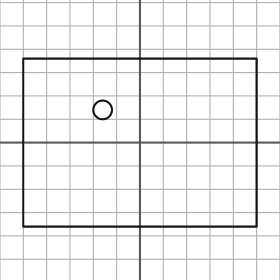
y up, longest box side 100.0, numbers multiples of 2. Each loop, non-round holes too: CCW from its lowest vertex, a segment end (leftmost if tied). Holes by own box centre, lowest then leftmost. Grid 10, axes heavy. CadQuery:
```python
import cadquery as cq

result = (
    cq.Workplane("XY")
    .moveTo(-50.0, -36.0)
    .lineTo(50.0, -36.0)
    .lineTo(50.0, 36.0)
    .lineTo(-50.0, 36.0)
    .close()
    .moveTo(-16.0, 14.0)
    .circle(4.0)
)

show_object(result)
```